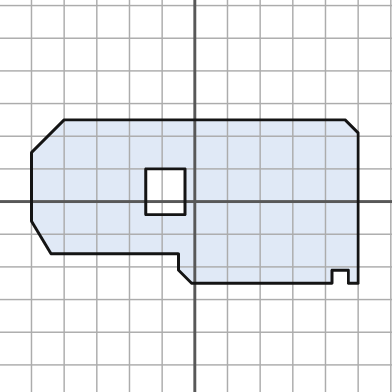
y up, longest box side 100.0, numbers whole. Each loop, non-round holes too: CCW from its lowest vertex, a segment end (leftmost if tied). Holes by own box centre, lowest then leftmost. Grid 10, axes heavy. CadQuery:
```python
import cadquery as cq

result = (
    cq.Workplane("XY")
    .moveTo(-1.0, -25.0)
    .lineTo(42.0, -25.0)
    .lineTo(42.0, -21.0)
    .lineTo(47.0, -21.0)
    .lineTo(47.0, -25.0)
    .lineTo(50.0, -25.0)
    .lineTo(50.0, 21.0)
    .lineTo(46.0, 25.0)
    .lineTo(-40.0, 25.0)
    .lineTo(-50.0, 15.0)
    .lineTo(-50.0, -6.0)
    .lineTo(-44.0, -16.0)
    .lineTo(-5.0, -16.0)
    .lineTo(-5.0, -21.0)
    .close()
    .moveTo(-15.0, -4.0)
    .lineTo(-3.0, -4.0)
    .lineTo(-3.0, 10.0)
    .lineTo(-15.0, 10.0)
    .close()
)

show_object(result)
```